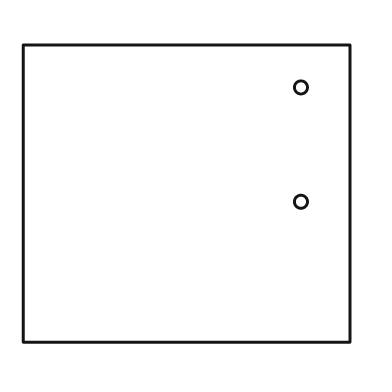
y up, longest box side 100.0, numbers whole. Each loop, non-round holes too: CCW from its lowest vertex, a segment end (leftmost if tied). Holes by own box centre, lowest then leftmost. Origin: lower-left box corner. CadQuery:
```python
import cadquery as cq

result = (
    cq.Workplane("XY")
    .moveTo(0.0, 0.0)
    .lineTo(100.0, 0.0)
    .lineTo(100.0, 91.0)
    .lineTo(0.0, 91.0)
    .close()
    .moveTo(85.0, 43.0)
    .circle(2.0)
    .moveTo(85.0, 78.0)
    .circle(2.0)
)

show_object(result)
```